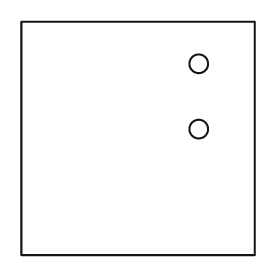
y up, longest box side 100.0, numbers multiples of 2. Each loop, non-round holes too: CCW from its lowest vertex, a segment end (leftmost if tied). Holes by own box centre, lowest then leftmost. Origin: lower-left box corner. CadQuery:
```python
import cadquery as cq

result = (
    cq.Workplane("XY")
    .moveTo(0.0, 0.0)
    .lineTo(100.0, 0.0)
    .lineTo(100.0, 100.0)
    .lineTo(0.0, 100.0)
    .close()
    .moveTo(76.0, 54.0)
    .circle(4.0)
    .moveTo(76.0, 82.0)
    .circle(4.0)
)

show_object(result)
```